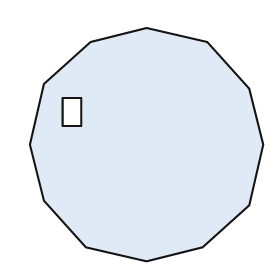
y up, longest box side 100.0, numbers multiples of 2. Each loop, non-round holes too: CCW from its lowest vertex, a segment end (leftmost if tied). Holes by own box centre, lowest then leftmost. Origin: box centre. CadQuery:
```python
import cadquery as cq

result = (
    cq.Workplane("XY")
    .moveTo(0.0, -50.0)
    .lineTo(24.0, -44.0)
    .lineTo(44.0, -26.0)
    .lineTo(50.0, 0.0)
    .lineTo(44.0, 24.0)
    .lineTo(26.0, 44.0)
    .lineTo(0.0, 50.0)
    .lineTo(-24.0, 44.0)
    .lineTo(-44.0, 26.0)
    .lineTo(-50.0, 0.0)
    .lineTo(-44.0, -24.0)
    .lineTo(-26.0, -44.0)
    .close()
    .moveTo(-36.0, 8.0)
    .lineTo(-28.0, 8.0)
    .lineTo(-28.0, 20.0)
    .lineTo(-36.0, 20.0)
    .close()
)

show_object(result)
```